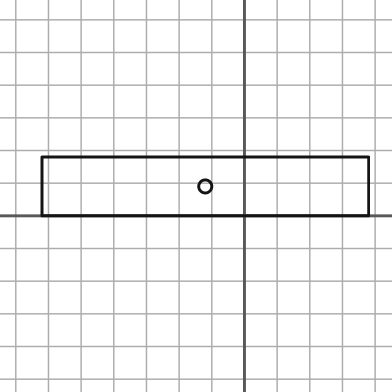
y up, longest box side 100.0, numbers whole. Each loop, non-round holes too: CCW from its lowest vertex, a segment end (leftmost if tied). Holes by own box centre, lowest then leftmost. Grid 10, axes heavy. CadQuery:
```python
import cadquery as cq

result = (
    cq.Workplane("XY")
    .moveTo(-62.0, 0.0)
    .lineTo(38.0, 0.0)
    .lineTo(38.0, 18.0)
    .lineTo(-62.0, 18.0)
    .close()
    .moveTo(-12.0, 9.0)
    .circle(2.0)
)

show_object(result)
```